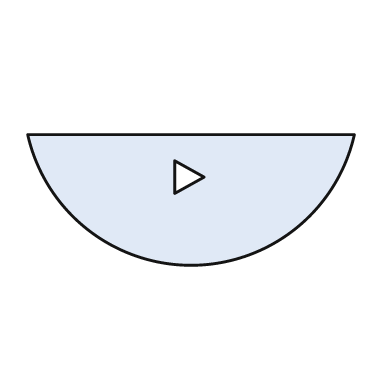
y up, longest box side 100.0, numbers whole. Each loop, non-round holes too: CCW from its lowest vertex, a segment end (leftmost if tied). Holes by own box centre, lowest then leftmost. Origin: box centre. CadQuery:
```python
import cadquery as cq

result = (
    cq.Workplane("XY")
    .moveTo(-50.0, 20.0)
    .threePointArc((0.0, -20.0), (50.0, 20.0))
    .close()
    .moveTo(-5.0, 2.0)
    .lineTo(4.0, 7.0)
    .lineTo(-5.0, 12.0)
    .close()
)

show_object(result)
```